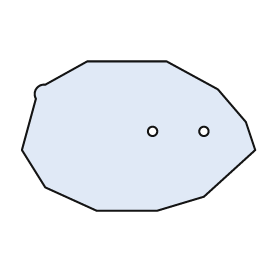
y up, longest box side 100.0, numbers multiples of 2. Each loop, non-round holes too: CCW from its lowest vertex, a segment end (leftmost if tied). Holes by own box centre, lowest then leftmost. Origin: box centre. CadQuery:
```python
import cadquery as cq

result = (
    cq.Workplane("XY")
    .moveTo(-18.0, -32.0)
    .lineTo(8.0, -32.0)
    .lineTo(28.0, -26.0)
    .lineTo(50.0, -6.0)
    .lineTo(46.0, 6.0)
    .lineTo(34.0, 20.0)
    .lineTo(12.0, 32.0)
    .lineTo(-22.0, 32.0)
    .lineTo(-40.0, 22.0)
    .threePointArc((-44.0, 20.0), (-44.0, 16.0))
    .lineTo(-50.0, -6.0)
    .lineTo(-40.0, -22.0)
    .close()
    .moveTo(6.0, 2.0)
    .circle(2.0)
    .moveTo(28.0, 2.0)
    .circle(2.0)
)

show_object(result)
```